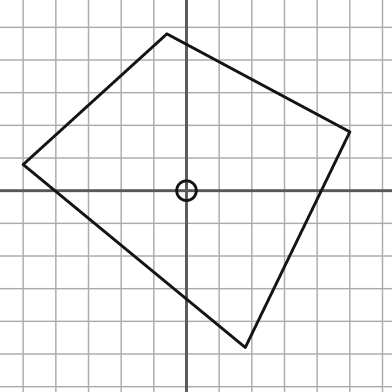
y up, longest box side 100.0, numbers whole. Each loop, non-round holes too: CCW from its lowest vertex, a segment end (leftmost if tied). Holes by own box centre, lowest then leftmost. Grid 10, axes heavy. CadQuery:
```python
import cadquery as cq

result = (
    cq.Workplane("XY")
    .moveTo(18.0, -48.0)
    .lineTo(50.0, 18.0)
    .lineTo(-6.0, 48.0)
    .lineTo(-50.0, 8.0)
    .close()
    .moveTo(0.0, 0.0)
    .circle(3.0)
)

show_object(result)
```